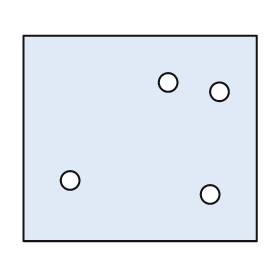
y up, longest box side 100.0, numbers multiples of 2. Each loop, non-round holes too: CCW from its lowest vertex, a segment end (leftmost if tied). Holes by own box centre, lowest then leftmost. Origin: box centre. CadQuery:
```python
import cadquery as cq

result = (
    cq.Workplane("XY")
    .moveTo(-50.0, -44.0)
    .lineTo(50.0, -44.0)
    .lineTo(50.0, 44.0)
    .lineTo(-50.0, 44.0)
    .close()
    .moveTo(30.0, -24.0)
    .circle(4.0)
    .moveTo(-30.0, -18.0)
    .circle(4.0)
    .moveTo(34.0, 20.0)
    .circle(4.0)
    .moveTo(12.0, 24.0)
    .circle(4.0)
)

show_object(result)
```